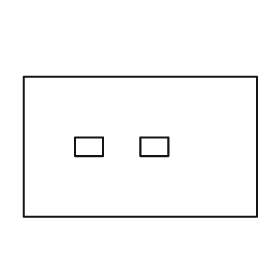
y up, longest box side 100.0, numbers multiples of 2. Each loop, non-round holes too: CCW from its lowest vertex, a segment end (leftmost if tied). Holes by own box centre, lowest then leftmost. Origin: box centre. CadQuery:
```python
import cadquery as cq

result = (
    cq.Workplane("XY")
    .moveTo(-50.0, -30.0)
    .lineTo(50.0, -30.0)
    .lineTo(50.0, 30.0)
    .lineTo(-50.0, 30.0)
    .close()
    .moveTo(-28.0, -4.0)
    .lineTo(-16.0, -4.0)
    .lineTo(-16.0, 4.0)
    .lineTo(-28.0, 4.0)
    .close()
    .moveTo(0.0, -4.0)
    .lineTo(12.0, -4.0)
    .lineTo(12.0, 4.0)
    .lineTo(0.0, 4.0)
    .close()
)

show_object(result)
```